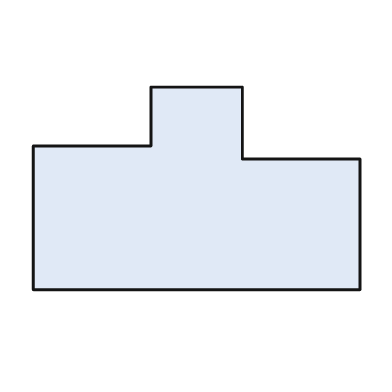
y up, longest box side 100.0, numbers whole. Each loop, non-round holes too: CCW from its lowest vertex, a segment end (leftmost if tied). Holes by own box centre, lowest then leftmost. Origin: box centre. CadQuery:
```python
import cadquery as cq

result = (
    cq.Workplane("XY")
    .moveTo(-50.0, -31.0)
    .lineTo(50.0, -31.0)
    .lineTo(50.0, 9.0)
    .lineTo(14.0, 9.0)
    .lineTo(14.0, 31.0)
    .lineTo(-14.0, 31.0)
    .lineTo(-14.0, 13.0)
    .lineTo(-50.0, 13.0)
    .close()
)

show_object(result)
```